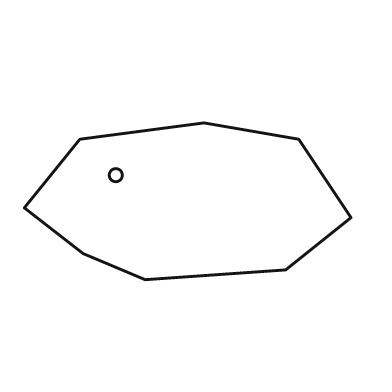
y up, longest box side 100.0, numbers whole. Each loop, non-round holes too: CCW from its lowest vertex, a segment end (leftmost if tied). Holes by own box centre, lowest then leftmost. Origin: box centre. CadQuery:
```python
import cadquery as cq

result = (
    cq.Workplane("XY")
    .moveTo(-13.0, -24.0)
    .lineTo(30.0, -21.0)
    .lineTo(50.0, -5.0)
    .lineTo(34.0, 19.0)
    .lineTo(5.0, 24.0)
    .lineTo(-33.0, 19.0)
    .lineTo(-50.0, -2.0)
    .lineTo(-32.0, -16.0)
    .close()
    .moveTo(-22.0, 8.0)
    .circle(2.0)
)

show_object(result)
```